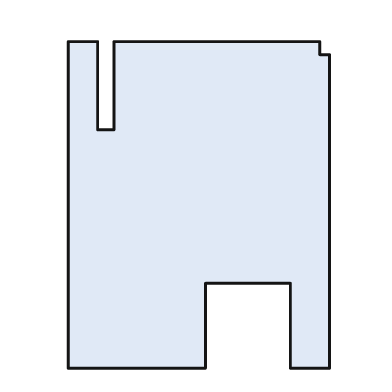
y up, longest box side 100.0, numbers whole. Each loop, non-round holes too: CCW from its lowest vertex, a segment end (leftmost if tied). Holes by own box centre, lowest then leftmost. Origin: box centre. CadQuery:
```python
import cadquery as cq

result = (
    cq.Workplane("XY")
    .moveTo(-40.0, -50.0)
    .lineTo(2.0, -50.0)
    .lineTo(2.0, -24.0)
    .lineTo(28.0, -24.0)
    .lineTo(28.0, -50.0)
    .lineTo(40.0, -50.0)
    .lineTo(40.0, 46.0)
    .lineTo(37.0, 46.0)
    .lineTo(37.0, 50.0)
    .lineTo(-26.0, 50.0)
    .lineTo(-26.0, 23.0)
    .lineTo(-31.0, 23.0)
    .lineTo(-31.0, 50.0)
    .lineTo(-40.0, 50.0)
    .close()
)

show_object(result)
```